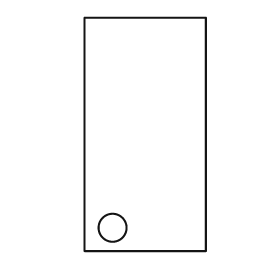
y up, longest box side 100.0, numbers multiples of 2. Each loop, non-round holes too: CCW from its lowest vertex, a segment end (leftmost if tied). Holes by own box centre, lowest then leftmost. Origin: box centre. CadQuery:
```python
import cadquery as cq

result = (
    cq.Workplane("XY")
    .moveTo(-26.0, -50.0)
    .lineTo(26.0, -50.0)
    .lineTo(26.0, 50.0)
    .lineTo(-26.0, 50.0)
    .close()
    .moveTo(-14.0, -40.0)
    .circle(6.0)
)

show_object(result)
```